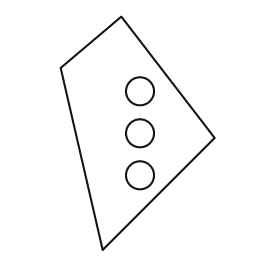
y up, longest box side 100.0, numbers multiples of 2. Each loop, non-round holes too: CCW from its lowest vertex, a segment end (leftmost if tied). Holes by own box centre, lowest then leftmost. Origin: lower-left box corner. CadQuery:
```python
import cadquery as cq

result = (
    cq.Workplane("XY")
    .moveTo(18.0, 0.0)
    .lineTo(66.0, 48.0)
    .lineTo(26.0, 100.0)
    .lineTo(0.0, 78.0)
    .close()
    .moveTo(34.0, 32.0)
    .circle(6.0)
    .moveTo(34.0, 50.0)
    .circle(6.0)
    .moveTo(34.0, 68.0)
    .circle(6.0)
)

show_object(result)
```